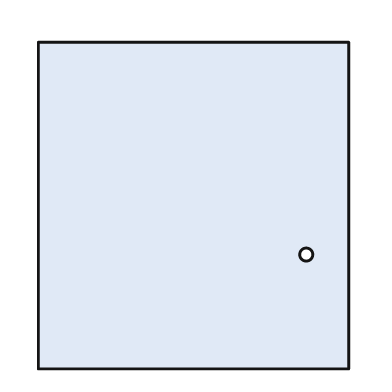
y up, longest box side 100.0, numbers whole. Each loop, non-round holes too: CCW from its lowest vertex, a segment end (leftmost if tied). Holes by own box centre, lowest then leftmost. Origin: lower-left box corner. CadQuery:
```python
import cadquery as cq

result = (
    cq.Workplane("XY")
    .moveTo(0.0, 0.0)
    .lineTo(95.0, 0.0)
    .lineTo(95.0, 100.0)
    .lineTo(0.0, 100.0)
    .close()
    .moveTo(82.0, 35.0)
    .circle(2.0)
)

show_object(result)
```